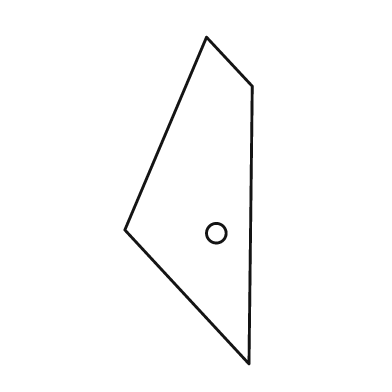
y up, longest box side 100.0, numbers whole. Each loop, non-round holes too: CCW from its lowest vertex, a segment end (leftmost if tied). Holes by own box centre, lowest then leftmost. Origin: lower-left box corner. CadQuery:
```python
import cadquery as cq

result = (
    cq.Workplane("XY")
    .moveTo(38.0, 0.0)
    .lineTo(39.0, 85.0)
    .lineTo(25.0, 100.0)
    .lineTo(0.0, 41.0)
    .close()
    .moveTo(28.0, 40.0)
    .circle(3.0)
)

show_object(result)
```